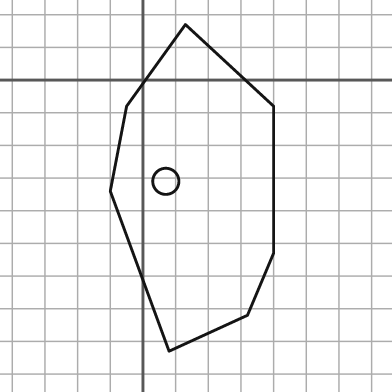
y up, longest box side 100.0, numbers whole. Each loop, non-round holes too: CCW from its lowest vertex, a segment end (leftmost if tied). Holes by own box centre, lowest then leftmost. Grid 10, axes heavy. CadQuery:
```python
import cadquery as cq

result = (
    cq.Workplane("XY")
    .moveTo(8.0, -83.0)
    .lineTo(32.0, -72.0)
    .lineTo(40.0, -53.0)
    .lineTo(40.0, -8.0)
    .lineTo(13.0, 17.0)
    .lineTo(-5.0, -8.0)
    .lineTo(-10.0, -34.0)
    .close()
    .moveTo(7.0, -31.0)
    .circle(4.0)
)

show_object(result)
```